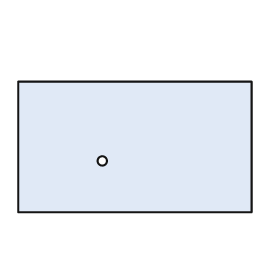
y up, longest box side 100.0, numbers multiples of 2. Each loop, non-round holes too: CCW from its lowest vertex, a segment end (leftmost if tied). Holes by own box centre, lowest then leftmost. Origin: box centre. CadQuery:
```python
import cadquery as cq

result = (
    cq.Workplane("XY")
    .moveTo(-50.0, -28.0)
    .lineTo(50.0, -28.0)
    .lineTo(50.0, 28.0)
    .lineTo(-50.0, 28.0)
    .close()
    .moveTo(-14.0, -6.0)
    .circle(2.0)
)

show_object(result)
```